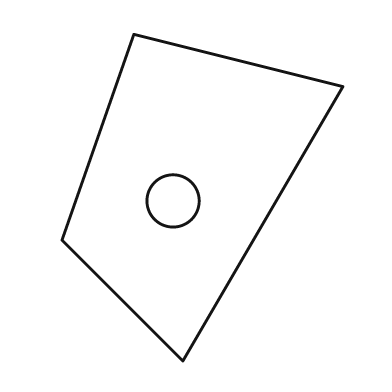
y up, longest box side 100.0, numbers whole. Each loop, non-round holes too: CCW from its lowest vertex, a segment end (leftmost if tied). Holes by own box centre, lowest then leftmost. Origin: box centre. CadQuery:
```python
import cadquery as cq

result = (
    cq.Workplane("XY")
    .moveTo(-6.0, -50.0)
    .lineTo(43.0, 34.0)
    .lineTo(-21.0, 50.0)
    .lineTo(-43.0, -13.0)
    .close()
    .moveTo(-9.0, -1.0)
    .circle(8.0)
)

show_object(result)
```